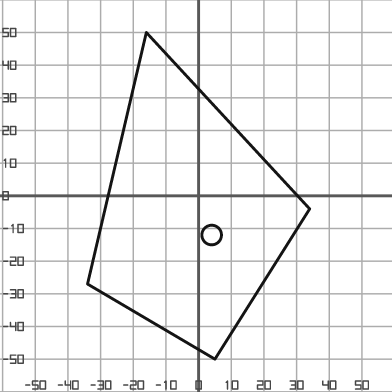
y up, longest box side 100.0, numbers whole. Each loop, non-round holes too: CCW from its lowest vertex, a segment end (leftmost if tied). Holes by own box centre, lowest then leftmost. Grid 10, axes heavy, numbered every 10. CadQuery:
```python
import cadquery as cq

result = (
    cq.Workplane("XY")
    .moveTo(5.0, -50.0)
    .lineTo(34.0, -4.0)
    .lineTo(-16.0, 50.0)
    .lineTo(-34.0, -27.0)
    .close()
    .moveTo(4.0, -12.0)
    .circle(3.0)
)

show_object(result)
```